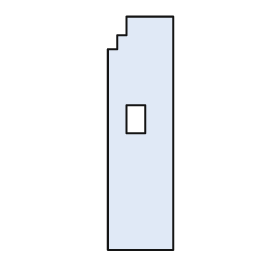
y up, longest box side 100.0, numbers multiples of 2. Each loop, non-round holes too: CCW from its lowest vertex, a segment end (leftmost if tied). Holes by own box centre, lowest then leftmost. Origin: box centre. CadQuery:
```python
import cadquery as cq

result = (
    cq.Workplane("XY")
    .moveTo(-14.0, -50.0)
    .lineTo(14.0, -50.0)
    .lineTo(14.0, 50.0)
    .lineTo(-6.0, 50.0)
    .lineTo(-6.0, 42.0)
    .lineTo(-10.0, 42.0)
    .lineTo(-10.0, 36.0)
    .lineTo(-14.0, 36.0)
    .close()
    .moveTo(-6.0, 0.0)
    .lineTo(2.0, 0.0)
    .lineTo(2.0, 12.0)
    .lineTo(-6.0, 12.0)
    .close()
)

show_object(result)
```